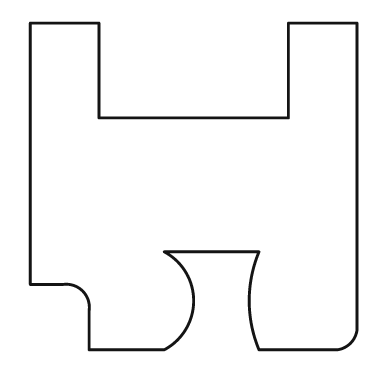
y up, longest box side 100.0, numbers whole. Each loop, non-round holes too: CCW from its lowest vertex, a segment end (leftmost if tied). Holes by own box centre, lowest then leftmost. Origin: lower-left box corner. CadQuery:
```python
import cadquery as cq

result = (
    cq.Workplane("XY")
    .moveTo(18.0, 0.0)
    .lineTo(41.0, 0.0)
    .threePointArc((50.0, 15.0), (41.0, 30.0))
    .lineTo(70.0, 30.0)
    .threePointArc((67.0, 15.0), (70.0, 0.0))
    .lineTo(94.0, 0.0)
    .threePointArc((98.0, 2.0), (100.0, 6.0))
    .lineTo(100.0, 100.0)
    .lineTo(79.0, 100.0)
    .lineTo(79.0, 71.0)
    .lineTo(21.0, 71.0)
    .lineTo(21.0, 100.0)
    .lineTo(0.0, 100.0)
    .lineTo(0.0, 20.0)
    .lineTo(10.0, 20.0)
    .threePointArc((16.0, 18.0), (18.0, 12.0))
    .close()
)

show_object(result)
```